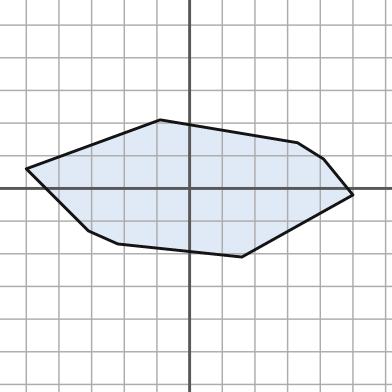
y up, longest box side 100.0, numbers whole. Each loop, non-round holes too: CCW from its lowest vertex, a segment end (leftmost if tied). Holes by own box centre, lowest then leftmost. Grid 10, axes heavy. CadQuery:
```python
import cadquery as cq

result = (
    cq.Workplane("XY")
    .moveTo(16.0, -21.0)
    .lineTo(50.0, -2.0)
    .lineTo(41.0, 9.0)
    .lineTo(33.0, 14.0)
    .lineTo(-9.0, 21.0)
    .lineTo(-50.0, 6.0)
    .lineTo(-31.0, -13.0)
    .lineTo(-22.0, -17.0)
    .close()
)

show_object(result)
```